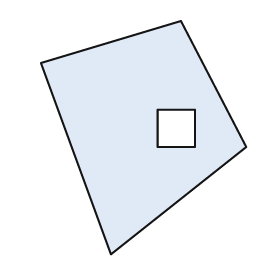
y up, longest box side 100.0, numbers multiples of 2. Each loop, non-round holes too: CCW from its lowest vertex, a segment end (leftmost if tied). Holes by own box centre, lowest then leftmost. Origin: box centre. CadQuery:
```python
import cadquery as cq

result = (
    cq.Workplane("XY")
    .moveTo(-14.0, -50.0)
    .lineTo(44.0, -4.0)
    .lineTo(16.0, 50.0)
    .lineTo(-44.0, 32.0)
    .close()
    .moveTo(6.0, -4.0)
    .lineTo(22.0, -4.0)
    .lineTo(22.0, 12.0)
    .lineTo(6.0, 12.0)
    .close()
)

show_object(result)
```